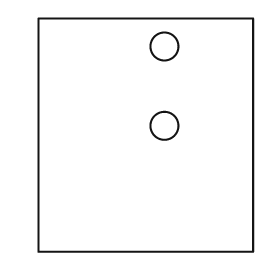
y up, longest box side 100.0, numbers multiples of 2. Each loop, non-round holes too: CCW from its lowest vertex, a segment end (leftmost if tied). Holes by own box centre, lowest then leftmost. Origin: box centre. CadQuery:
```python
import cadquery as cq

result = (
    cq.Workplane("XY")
    .moveTo(-46.0, -50.0)
    .lineTo(46.0, -50.0)
    .lineTo(46.0, 50.0)
    .lineTo(-46.0, 50.0)
    .close()
    .moveTo(8.0, 4.0)
    .circle(6.0)
    .moveTo(8.0, 38.0)
    .circle(6.0)
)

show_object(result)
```